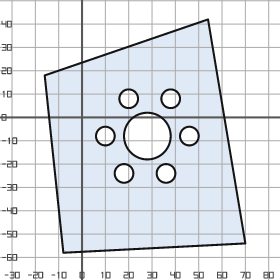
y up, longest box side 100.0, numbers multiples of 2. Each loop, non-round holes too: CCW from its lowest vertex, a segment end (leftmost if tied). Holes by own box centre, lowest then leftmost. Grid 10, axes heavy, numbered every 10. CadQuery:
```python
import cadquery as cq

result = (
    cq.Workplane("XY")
    .moveTo(-8.0, -58.0)
    .lineTo(70.0, -54.0)
    .lineTo(54.0, 42.0)
    .lineTo(-16.0, 18.0)
    .close()
    .moveTo(18.0, -24.0)
    .circle(4.0)
    .moveTo(36.0, -24.0)
    .circle(4.0)
    .moveTo(10.0, -8.0)
    .circle(4.0)
    .moveTo(28.0, -8.0)
    .circle(10.0)
    .moveTo(46.0, -8.0)
    .circle(4.0)
    .moveTo(20.0, 8.0)
    .circle(4.0)
    .moveTo(38.0, 8.0)
    .circle(4.0)
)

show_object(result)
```